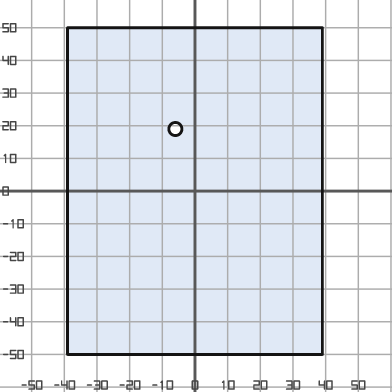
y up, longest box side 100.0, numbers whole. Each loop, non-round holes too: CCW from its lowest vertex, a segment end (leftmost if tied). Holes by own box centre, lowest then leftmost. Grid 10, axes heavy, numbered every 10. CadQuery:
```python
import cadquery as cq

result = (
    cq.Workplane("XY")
    .moveTo(-39.0, -50.0)
    .lineTo(39.0, -50.0)
    .lineTo(39.0, 50.0)
    .lineTo(-39.0, 50.0)
    .close()
    .moveTo(-6.0, 19.0)
    .circle(2.0)
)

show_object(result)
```